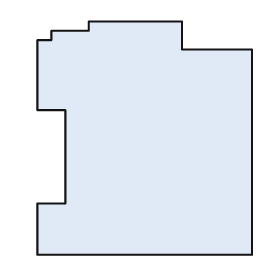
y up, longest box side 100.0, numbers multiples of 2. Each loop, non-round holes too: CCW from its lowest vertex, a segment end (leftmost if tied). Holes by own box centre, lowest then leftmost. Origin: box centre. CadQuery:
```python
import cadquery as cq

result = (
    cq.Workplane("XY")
    .moveTo(-46.0, -50.0)
    .lineTo(46.0, -50.0)
    .lineTo(46.0, 38.0)
    .lineTo(16.0, 38.0)
    .lineTo(16.0, 50.0)
    .lineTo(-24.0, 50.0)
    .lineTo(-24.0, 46.0)
    .lineTo(-40.0, 46.0)
    .lineTo(-40.0, 42.0)
    .lineTo(-46.0, 42.0)
    .lineTo(-46.0, 12.0)
    .lineTo(-34.0, 12.0)
    .lineTo(-34.0, -28.0)
    .lineTo(-46.0, -28.0)
    .close()
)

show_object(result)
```